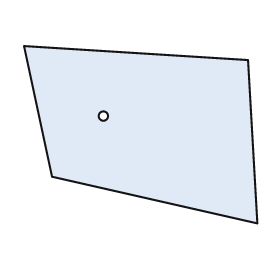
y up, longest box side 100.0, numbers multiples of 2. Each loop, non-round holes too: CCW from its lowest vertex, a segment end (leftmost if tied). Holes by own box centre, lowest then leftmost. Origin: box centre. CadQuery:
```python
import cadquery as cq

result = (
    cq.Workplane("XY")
    .moveTo(50.0, -38.0)
    .lineTo(46.0, 32.0)
    .lineTo(-50.0, 38.0)
    .lineTo(-38.0, -18.0)
    .close()
    .moveTo(-16.0, 8.0)
    .circle(2.0)
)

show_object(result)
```